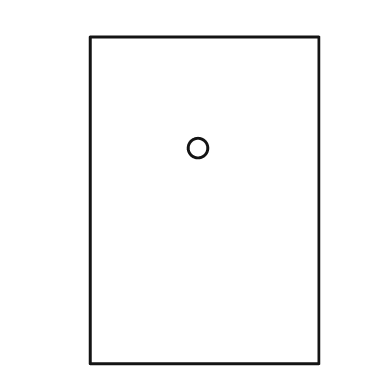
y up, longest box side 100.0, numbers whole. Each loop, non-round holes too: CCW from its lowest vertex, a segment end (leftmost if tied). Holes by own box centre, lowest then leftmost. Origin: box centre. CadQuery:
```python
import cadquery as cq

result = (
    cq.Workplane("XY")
    .moveTo(-35.0, -50.0)
    .lineTo(35.0, -50.0)
    .lineTo(35.0, 50.0)
    .lineTo(-35.0, 50.0)
    .close()
    .moveTo(-2.0, 16.0)
    .circle(3.0)
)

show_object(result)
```